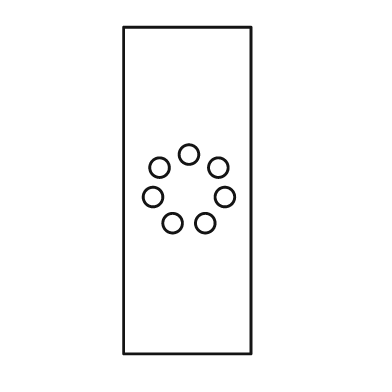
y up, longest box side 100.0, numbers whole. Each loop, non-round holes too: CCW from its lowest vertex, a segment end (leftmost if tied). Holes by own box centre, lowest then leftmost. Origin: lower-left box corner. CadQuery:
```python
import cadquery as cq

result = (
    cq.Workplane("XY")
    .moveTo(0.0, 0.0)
    .lineTo(39.0, 0.0)
    .lineTo(39.0, 100.0)
    .lineTo(0.0, 100.0)
    .close()
    .moveTo(15.0, 40.0)
    .circle(3.0)
    .moveTo(25.0, 40.0)
    .circle(3.0)
    .moveTo(9.0, 48.0)
    .circle(3.0)
    .moveTo(31.0, 48.0)
    .circle(3.0)
    .moveTo(11.0, 57.0)
    .circle(3.0)
    .moveTo(29.0, 57.0)
    .circle(3.0)
    .moveTo(20.0, 61.0)
    .circle(3.0)
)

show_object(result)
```